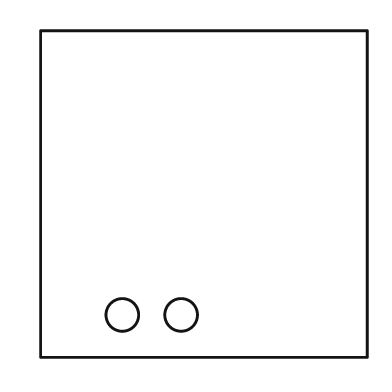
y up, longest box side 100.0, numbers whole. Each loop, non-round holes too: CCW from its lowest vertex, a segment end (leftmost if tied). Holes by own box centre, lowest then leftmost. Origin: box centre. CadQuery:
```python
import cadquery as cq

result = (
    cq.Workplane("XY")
    .moveTo(-50.0, -50.0)
    .lineTo(50.0, -50.0)
    .lineTo(50.0, 50.0)
    .lineTo(-50.0, 50.0)
    .close()
    .moveTo(-25.0, -37.0)
    .circle(5.0)
    .moveTo(-7.0, -37.0)
    .circle(5.0)
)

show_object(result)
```